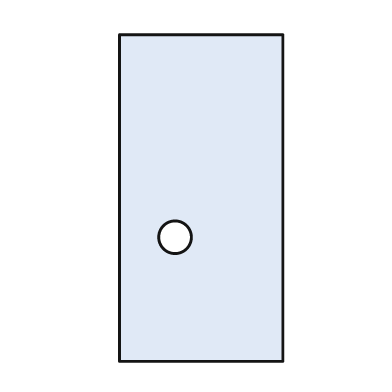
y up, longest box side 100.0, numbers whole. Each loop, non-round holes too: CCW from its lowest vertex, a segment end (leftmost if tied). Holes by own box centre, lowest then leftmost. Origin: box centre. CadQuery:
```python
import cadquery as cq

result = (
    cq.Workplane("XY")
    .moveTo(-25.0, -50.0)
    .lineTo(25.0, -50.0)
    .lineTo(25.0, 50.0)
    .lineTo(-25.0, 50.0)
    .close()
    .moveTo(-8.0, -12.0)
    .circle(5.0)
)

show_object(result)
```